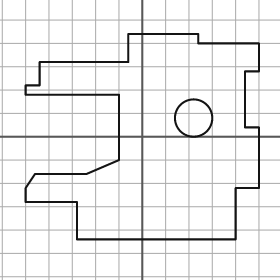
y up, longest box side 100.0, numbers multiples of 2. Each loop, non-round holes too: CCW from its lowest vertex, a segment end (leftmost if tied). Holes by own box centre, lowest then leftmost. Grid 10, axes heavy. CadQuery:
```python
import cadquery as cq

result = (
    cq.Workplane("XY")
    .moveTo(-28.0, -44.0)
    .lineTo(40.0, -44.0)
    .lineTo(40.0, -22.0)
    .lineTo(50.0, -22.0)
    .lineTo(50.0, 4.0)
    .lineTo(44.0, 4.0)
    .lineTo(44.0, 28.0)
    .lineTo(50.0, 28.0)
    .lineTo(50.0, 40.0)
    .lineTo(24.0, 40.0)
    .lineTo(24.0, 44.0)
    .lineTo(-6.0, 44.0)
    .lineTo(-6.0, 32.0)
    .lineTo(-44.0, 32.0)
    .lineTo(-44.0, 22.0)
    .lineTo(-50.0, 22.0)
    .lineTo(-50.0, 18.0)
    .lineTo(-10.0, 18.0)
    .lineTo(-10.0, -10.0)
    .lineTo(-24.0, -16.0)
    .lineTo(-46.0, -16.0)
    .lineTo(-50.0, -22.0)
    .lineTo(-50.0, -28.0)
    .lineTo(-28.0, -28.0)
    .close()
    .moveTo(22.0, 8.0)
    .circle(8.0)
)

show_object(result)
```